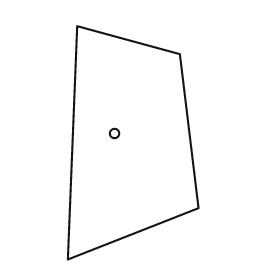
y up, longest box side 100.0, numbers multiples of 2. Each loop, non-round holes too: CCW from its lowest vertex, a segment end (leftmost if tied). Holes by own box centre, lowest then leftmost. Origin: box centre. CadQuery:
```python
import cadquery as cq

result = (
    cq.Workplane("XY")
    .moveTo(-28.0, -50.0)
    .lineTo(28.0, -28.0)
    .lineTo(20.0, 38.0)
    .lineTo(-24.0, 50.0)
    .close()
    .moveTo(-8.0, 4.0)
    .circle(2.0)
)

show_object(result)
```